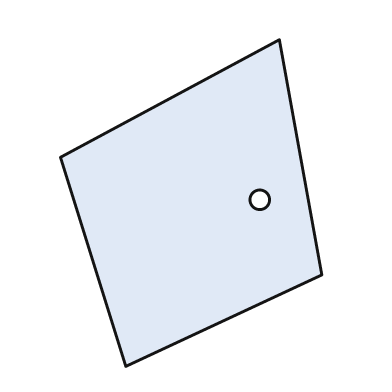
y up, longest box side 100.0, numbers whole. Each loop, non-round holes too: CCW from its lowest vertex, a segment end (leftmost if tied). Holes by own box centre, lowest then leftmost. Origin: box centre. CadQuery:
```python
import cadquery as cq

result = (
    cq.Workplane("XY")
    .moveTo(-20.0, -50.0)
    .lineTo(40.0, -22.0)
    .lineTo(27.0, 50.0)
    .lineTo(-40.0, 14.0)
    .close()
    .moveTo(21.0, 1.0)
    .circle(3.0)
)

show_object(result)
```